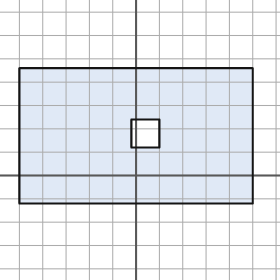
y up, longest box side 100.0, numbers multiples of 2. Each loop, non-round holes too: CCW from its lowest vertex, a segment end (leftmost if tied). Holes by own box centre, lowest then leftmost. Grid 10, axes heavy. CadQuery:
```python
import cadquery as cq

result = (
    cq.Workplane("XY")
    .moveTo(-50.0, -12.0)
    .lineTo(50.0, -12.0)
    .lineTo(50.0, 46.0)
    .lineTo(-50.0, 46.0)
    .close()
    .moveTo(-2.0, 12.0)
    .lineTo(10.0, 12.0)
    .lineTo(10.0, 24.0)
    .lineTo(-2.0, 24.0)
    .close()
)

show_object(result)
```